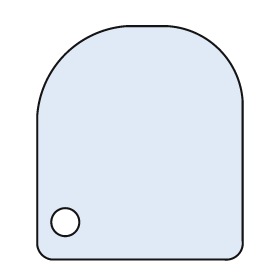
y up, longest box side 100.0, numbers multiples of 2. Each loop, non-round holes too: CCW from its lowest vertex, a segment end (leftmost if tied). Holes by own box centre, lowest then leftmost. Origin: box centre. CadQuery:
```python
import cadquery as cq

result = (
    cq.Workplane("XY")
    .moveTo(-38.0, -50.0)
    .lineTo(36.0, -50.0)
    .threePointArc((42.0, -48.0), (44.0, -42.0))
    .lineTo(44.0, 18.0)
    .threePointArc((34.0, 40.0), (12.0, 50.0))
    .lineTo(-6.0, 50.0)
    .threePointArc((-32.0, 38.0), (-44.0, 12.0))
    .lineTo(-44.0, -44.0)
    .threePointArc((-42.0, -48.0), (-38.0, -50.0))
    .close()
    .moveTo(-32.0, -34.0)
    .circle(6.0)
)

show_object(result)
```